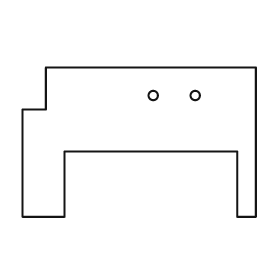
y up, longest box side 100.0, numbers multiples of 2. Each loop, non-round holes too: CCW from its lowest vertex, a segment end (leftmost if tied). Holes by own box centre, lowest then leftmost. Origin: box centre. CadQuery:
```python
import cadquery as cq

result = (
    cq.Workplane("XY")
    .moveTo(-50.0, -32.0)
    .lineTo(-32.0, -32.0)
    .lineTo(-32.0, -4.0)
    .lineTo(42.0, -4.0)
    .lineTo(42.0, -32.0)
    .lineTo(50.0, -32.0)
    .lineTo(50.0, 32.0)
    .lineTo(-40.0, 32.0)
    .lineTo(-40.0, 14.0)
    .lineTo(-50.0, 14.0)
    .close()
    .moveTo(6.0, 20.0)
    .circle(2.0)
    .moveTo(24.0, 20.0)
    .circle(2.0)
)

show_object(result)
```